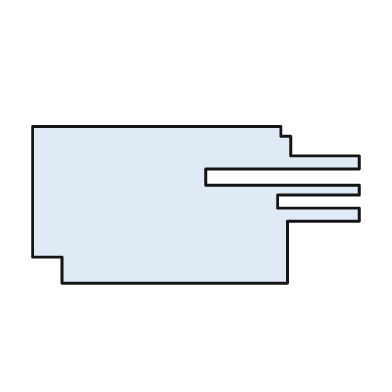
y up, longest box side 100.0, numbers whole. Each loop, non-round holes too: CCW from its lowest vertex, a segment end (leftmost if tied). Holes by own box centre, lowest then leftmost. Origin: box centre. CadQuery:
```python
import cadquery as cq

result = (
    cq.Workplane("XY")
    .moveTo(-41.0, -24.0)
    .lineTo(28.0, -24.0)
    .lineTo(28.0, -5.0)
    .lineTo(50.0, -5.0)
    .lineTo(50.0, -1.0)
    .lineTo(25.0, -1.0)
    .lineTo(25.0, 3.0)
    .lineTo(50.0, 3.0)
    .lineTo(50.0, 6.0)
    .lineTo(3.0, 6.0)
    .lineTo(3.0, 11.0)
    .lineTo(50.0, 11.0)
    .lineTo(50.0, 15.0)
    .lineTo(29.0, 15.0)
    .lineTo(29.0, 21.0)
    .lineTo(26.0, 21.0)
    .lineTo(26.0, 24.0)
    .lineTo(-50.0, 24.0)
    .lineTo(-50.0, -16.0)
    .lineTo(-41.0, -16.0)
    .close()
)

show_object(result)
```